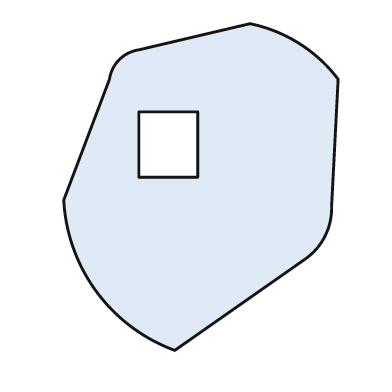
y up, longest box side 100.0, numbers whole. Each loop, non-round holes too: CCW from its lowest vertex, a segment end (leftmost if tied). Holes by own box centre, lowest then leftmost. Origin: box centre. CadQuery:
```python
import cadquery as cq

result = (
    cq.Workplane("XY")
    .moveTo(-8.0, -50.0)
    .lineTo(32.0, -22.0)
    .threePointArc((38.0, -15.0), (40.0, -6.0))
    .lineTo(42.0, 33.0)
    .threePointArc((30.0, 44.0), (15.0, 50.0))
    .lineTo(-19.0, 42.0)
    .threePointArc((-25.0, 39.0), (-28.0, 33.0))
    .lineTo(-42.0, -4.0)
    .threePointArc((-32.0, -32.0), (-8.0, -50.0))
    .close()
    .moveTo(-19.0, 3.0)
    .lineTo(-1.0, 3.0)
    .lineTo(-1.0, 23.0)
    .lineTo(-19.0, 23.0)
    .close()
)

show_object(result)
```